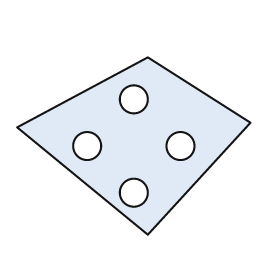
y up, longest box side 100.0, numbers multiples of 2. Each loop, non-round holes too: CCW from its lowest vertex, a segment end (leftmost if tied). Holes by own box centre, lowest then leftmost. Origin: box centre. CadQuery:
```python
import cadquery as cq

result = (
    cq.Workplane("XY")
    .moveTo(6.0, -38.0)
    .lineTo(50.0, 10.0)
    .lineTo(6.0, 38.0)
    .lineTo(-50.0, 8.0)
    .close()
    .moveTo(0.0, -20.0)
    .circle(6.0)
    .moveTo(-20.0, 0.0)
    .circle(6.0)
    .moveTo(20.0, 0.0)
    .circle(6.0)
    .moveTo(0.0, 20.0)
    .circle(6.0)
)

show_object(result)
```